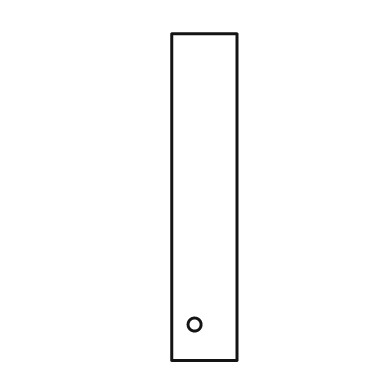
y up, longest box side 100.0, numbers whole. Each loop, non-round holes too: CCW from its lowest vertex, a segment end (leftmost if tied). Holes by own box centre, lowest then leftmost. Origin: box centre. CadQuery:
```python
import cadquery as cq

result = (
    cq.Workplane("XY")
    .moveTo(-10.0, -50.0)
    .lineTo(10.0, -50.0)
    .lineTo(10.0, 50.0)
    .lineTo(-10.0, 50.0)
    .close()
    .moveTo(-3.0, -39.0)
    .circle(2.0)
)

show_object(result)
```